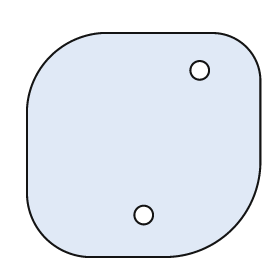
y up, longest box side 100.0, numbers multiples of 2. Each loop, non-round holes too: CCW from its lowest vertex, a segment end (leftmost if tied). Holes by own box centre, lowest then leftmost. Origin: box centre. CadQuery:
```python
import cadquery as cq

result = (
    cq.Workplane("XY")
    .moveTo(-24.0, -48.0)
    .lineTo(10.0, -48.0)
    .threePointArc((38.0, -36.0), (50.0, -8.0))
    .lineTo(50.0, 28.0)
    .threePointArc((44.0, 42.0), (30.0, 48.0))
    .lineTo(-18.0, 48.0)
    .threePointArc((-40.0, 38.0), (-50.0, 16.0))
    .lineTo(-50.0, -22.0)
    .threePointArc((-42.0, -40.0), (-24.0, -48.0))
    .close()
    .moveTo(0.0, -30.0)
    .circle(4.0)
    .moveTo(24.0, 32.0)
    .circle(4.0)
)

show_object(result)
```